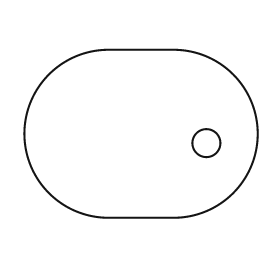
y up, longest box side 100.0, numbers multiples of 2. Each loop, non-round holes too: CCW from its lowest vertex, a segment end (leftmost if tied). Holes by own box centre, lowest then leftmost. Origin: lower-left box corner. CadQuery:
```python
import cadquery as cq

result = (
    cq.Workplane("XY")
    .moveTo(36.0, 0.0)
    .lineTo(64.0, 0.0)
    .threePointArc((100.0, 36.0), (64.0, 72.0))
    .lineTo(36.0, 72.0)
    .threePointArc((0.0, 36.0), (36.0, 0.0))
    .close()
    .moveTo(78.0, 32.0)
    .circle(6.0)
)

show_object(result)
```